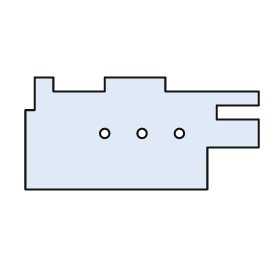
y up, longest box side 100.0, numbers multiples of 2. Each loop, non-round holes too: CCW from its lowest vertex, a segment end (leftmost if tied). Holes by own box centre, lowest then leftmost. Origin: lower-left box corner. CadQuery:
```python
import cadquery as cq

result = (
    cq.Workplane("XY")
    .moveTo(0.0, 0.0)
    .lineTo(78.0, 0.0)
    .lineTo(78.0, 18.0)
    .lineTo(100.0, 18.0)
    .lineTo(100.0, 30.0)
    .lineTo(82.0, 30.0)
    .lineTo(82.0, 36.0)
    .lineTo(100.0, 36.0)
    .lineTo(100.0, 42.0)
    .lineTo(60.0, 42.0)
    .lineTo(60.0, 48.0)
    .lineTo(34.0, 48.0)
    .lineTo(34.0, 42.0)
    .lineTo(12.0, 42.0)
    .lineTo(12.0, 48.0)
    .lineTo(4.0, 48.0)
    .lineTo(4.0, 34.0)
    .lineTo(0.0, 34.0)
    .close()
    .moveTo(34.0, 24.0)
    .circle(2.0)
    .moveTo(50.0, 24.0)
    .circle(2.0)
    .moveTo(66.0, 24.0)
    .circle(2.0)
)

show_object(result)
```